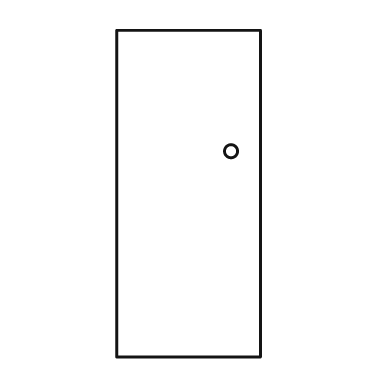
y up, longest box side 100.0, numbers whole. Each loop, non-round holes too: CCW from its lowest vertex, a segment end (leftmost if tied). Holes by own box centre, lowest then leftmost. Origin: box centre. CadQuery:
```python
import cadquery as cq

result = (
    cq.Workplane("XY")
    .moveTo(-22.0, -50.0)
    .lineTo(22.0, -50.0)
    .lineTo(22.0, 50.0)
    .lineTo(-22.0, 50.0)
    .close()
    .moveTo(13.0, 13.0)
    .circle(2.0)
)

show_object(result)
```